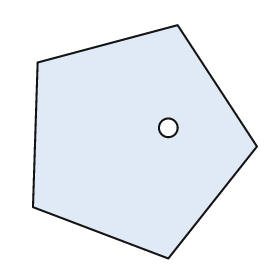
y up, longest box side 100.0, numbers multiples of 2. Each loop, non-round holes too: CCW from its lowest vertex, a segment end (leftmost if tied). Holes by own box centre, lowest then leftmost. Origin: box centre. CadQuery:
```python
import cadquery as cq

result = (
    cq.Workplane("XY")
    .moveTo(10.0, -50.0)
    .lineTo(48.0, -2.0)
    .lineTo(14.0, 50.0)
    .lineTo(-46.0, 34.0)
    .lineTo(-48.0, -28.0)
    .close()
    .moveTo(10.0, 6.0)
    .circle(4.0)
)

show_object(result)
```